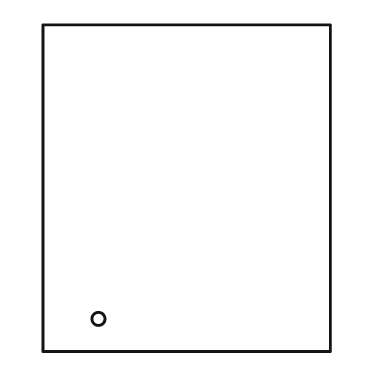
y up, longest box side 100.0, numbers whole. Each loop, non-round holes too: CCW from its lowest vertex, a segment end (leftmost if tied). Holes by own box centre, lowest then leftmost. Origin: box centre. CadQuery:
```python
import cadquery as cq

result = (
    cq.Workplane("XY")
    .moveTo(-44.0, -50.0)
    .lineTo(44.0, -50.0)
    .lineTo(44.0, 50.0)
    .lineTo(-44.0, 50.0)
    .close()
    .moveTo(-27.0, -40.0)
    .circle(2.0)
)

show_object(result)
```